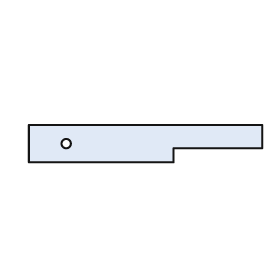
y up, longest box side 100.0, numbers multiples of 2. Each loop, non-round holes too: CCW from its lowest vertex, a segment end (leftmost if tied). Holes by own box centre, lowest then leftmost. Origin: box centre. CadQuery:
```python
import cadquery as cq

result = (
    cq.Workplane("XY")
    .moveTo(-50.0, -8.0)
    .lineTo(12.0, -8.0)
    .lineTo(12.0, -2.0)
    .lineTo(50.0, -2.0)
    .lineTo(50.0, 8.0)
    .lineTo(-50.0, 8.0)
    .close()
    .moveTo(-34.0, 0.0)
    .circle(2.0)
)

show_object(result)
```